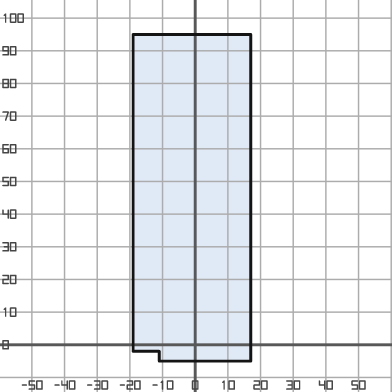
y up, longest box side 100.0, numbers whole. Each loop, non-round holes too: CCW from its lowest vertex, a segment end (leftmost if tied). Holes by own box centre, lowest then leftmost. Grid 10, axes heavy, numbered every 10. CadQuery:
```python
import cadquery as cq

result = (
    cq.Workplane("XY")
    .moveTo(-11.0, -5.0)
    .lineTo(17.0, -5.0)
    .lineTo(17.0, 95.0)
    .lineTo(-19.0, 95.0)
    .lineTo(-19.0, -2.0)
    .lineTo(-11.0, -2.0)
    .close()
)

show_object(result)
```